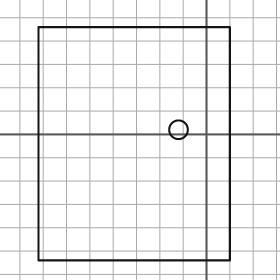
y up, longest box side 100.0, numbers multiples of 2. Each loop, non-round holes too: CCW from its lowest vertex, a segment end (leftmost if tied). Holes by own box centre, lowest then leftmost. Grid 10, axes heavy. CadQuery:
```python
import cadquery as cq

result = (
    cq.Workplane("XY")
    .moveTo(-72.0, -54.0)
    .lineTo(10.0, -54.0)
    .lineTo(10.0, 46.0)
    .lineTo(-72.0, 46.0)
    .close()
    .moveTo(-12.0, 2.0)
    .circle(4.0)
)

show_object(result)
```